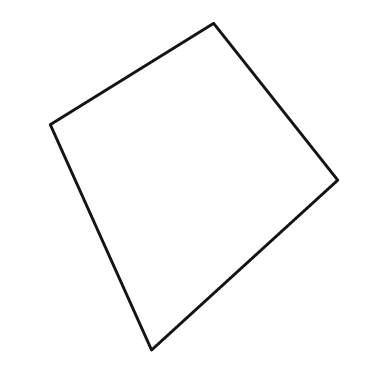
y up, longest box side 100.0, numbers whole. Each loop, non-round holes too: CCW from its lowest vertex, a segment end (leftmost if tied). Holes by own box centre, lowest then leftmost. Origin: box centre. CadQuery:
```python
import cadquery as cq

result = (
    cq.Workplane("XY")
    .moveTo(-13.0, -50.0)
    .lineTo(44.0, 2.0)
    .lineTo(6.0, 50.0)
    .lineTo(-44.0, 19.0)
    .close()
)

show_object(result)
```